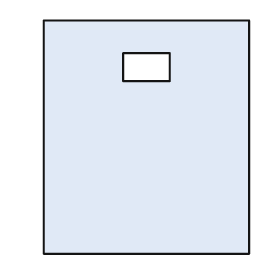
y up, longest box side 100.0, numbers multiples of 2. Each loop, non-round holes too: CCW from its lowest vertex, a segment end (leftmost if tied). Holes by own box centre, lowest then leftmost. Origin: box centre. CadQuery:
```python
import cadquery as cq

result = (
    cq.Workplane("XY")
    .moveTo(-44.0, -50.0)
    .lineTo(44.0, -50.0)
    .lineTo(44.0, 50.0)
    .lineTo(-44.0, 50.0)
    .close()
    .moveTo(-10.0, 24.0)
    .lineTo(10.0, 24.0)
    .lineTo(10.0, 36.0)
    .lineTo(-10.0, 36.0)
    .close()
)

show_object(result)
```